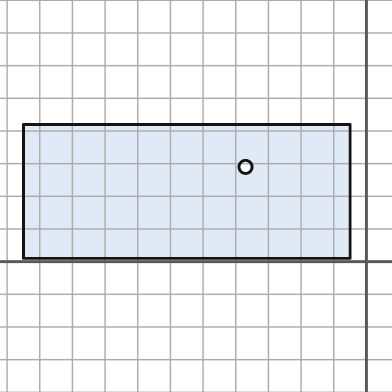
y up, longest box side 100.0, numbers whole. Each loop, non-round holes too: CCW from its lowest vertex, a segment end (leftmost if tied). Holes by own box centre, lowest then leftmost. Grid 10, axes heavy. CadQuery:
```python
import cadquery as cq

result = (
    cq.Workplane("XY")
    .moveTo(-105.0, 1.0)
    .lineTo(-5.0, 1.0)
    .lineTo(-5.0, 42.0)
    .lineTo(-105.0, 42.0)
    .close()
    .moveTo(-37.0, 29.0)
    .circle(2.0)
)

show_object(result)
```